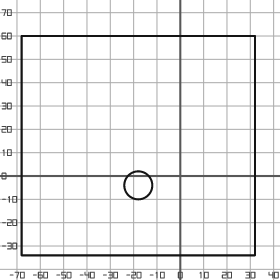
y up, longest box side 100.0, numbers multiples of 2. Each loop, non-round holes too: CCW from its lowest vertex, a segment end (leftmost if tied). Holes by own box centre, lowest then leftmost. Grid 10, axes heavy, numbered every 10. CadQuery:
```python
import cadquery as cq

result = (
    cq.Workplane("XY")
    .moveTo(-68.0, -34.0)
    .lineTo(32.0, -34.0)
    .lineTo(32.0, 60.0)
    .lineTo(-68.0, 60.0)
    .close()
    .moveTo(-18.0, -4.0)
    .circle(6.0)
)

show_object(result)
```